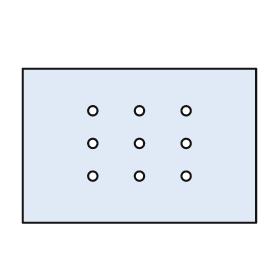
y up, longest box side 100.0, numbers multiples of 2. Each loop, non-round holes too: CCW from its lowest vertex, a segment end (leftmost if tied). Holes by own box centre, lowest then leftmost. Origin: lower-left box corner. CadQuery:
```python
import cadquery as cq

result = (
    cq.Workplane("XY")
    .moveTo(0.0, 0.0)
    .lineTo(100.0, 0.0)
    .lineTo(100.0, 66.0)
    .lineTo(0.0, 66.0)
    .close()
    .moveTo(30.0, 20.0)
    .circle(2.0)
    .moveTo(50.0, 20.0)
    .circle(2.0)
    .moveTo(70.0, 20.0)
    .circle(2.0)
    .moveTo(30.0, 34.0)
    .circle(2.0)
    .moveTo(50.0, 34.0)
    .circle(2.0)
    .moveTo(70.0, 34.0)
    .circle(2.0)
    .moveTo(30.0, 48.0)
    .circle(2.0)
    .moveTo(50.0, 48.0)
    .circle(2.0)
    .moveTo(70.0, 48.0)
    .circle(2.0)
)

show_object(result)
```